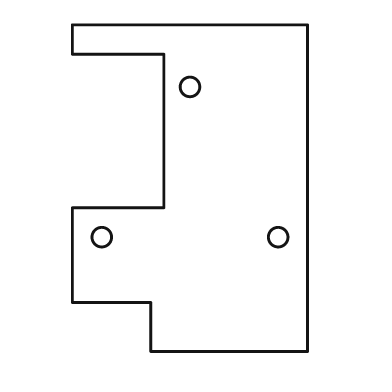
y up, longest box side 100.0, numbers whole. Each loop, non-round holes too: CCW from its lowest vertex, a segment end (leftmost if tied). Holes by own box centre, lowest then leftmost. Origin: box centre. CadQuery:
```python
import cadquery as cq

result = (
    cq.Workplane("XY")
    .moveTo(-12.0, -50.0)
    .lineTo(36.0, -50.0)
    .lineTo(36.0, 50.0)
    .lineTo(-36.0, 50.0)
    .lineTo(-36.0, 41.0)
    .lineTo(-8.0, 41.0)
    .lineTo(-8.0, -6.0)
    .lineTo(-36.0, -6.0)
    .lineTo(-36.0, -35.0)
    .lineTo(-12.0, -35.0)
    .close()
    .moveTo(-27.0, -15.0)
    .circle(3.0)
    .moveTo(27.0, -15.0)
    .circle(3.0)
    .moveTo(0.0, 31.0)
    .circle(3.0)
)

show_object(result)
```